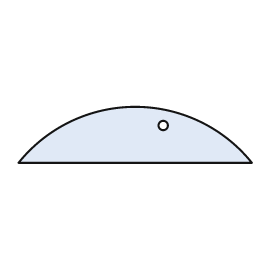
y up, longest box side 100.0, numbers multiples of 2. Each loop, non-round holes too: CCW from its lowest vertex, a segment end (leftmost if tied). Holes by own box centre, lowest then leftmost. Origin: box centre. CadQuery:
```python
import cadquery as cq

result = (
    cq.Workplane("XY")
    .moveTo(-50.0, -12.0)
    .lineTo(50.0, -12.0)
    .threePointArc((0.0, 12.0), (-50.0, -12.0))
    .close()
    .moveTo(12.0, 4.0)
    .circle(2.0)
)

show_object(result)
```